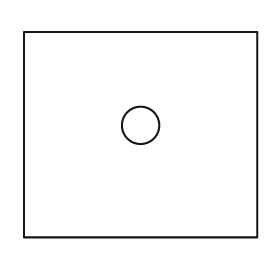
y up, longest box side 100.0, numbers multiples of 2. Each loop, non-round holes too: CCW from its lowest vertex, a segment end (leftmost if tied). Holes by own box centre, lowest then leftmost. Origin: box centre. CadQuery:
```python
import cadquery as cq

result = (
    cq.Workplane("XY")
    .moveTo(-50.0, -44.0)
    .lineTo(50.0, -44.0)
    .lineTo(50.0, 44.0)
    .lineTo(-50.0, 44.0)
    .close()
    .moveTo(0.0, 4.0)
    .circle(8.0)
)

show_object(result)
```